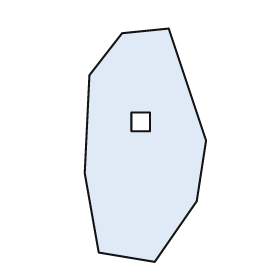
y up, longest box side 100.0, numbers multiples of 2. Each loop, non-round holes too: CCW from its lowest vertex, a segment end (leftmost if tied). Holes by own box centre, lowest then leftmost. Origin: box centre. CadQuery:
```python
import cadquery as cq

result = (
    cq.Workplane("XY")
    .moveTo(4.0, -50.0)
    .lineTo(22.0, -24.0)
    .lineTo(26.0, 2.0)
    .lineTo(10.0, 50.0)
    .lineTo(-10.0, 48.0)
    .lineTo(-24.0, 30.0)
    .lineTo(-26.0, -12.0)
    .lineTo(-20.0, -46.0)
    .close()
    .moveTo(-6.0, 6.0)
    .lineTo(2.0, 6.0)
    .lineTo(2.0, 14.0)
    .lineTo(-6.0, 14.0)
    .close()
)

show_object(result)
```